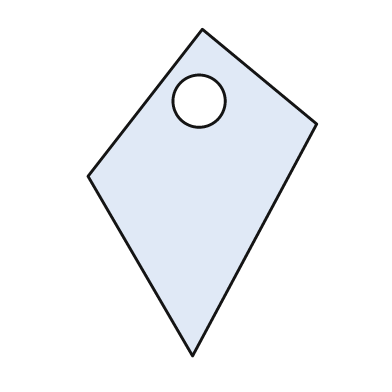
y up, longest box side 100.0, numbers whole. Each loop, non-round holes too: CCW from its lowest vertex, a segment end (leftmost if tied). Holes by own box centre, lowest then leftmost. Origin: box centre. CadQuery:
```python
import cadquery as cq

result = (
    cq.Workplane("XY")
    .moveTo(-3.0, -50.0)
    .lineTo(35.0, 21.0)
    .lineTo(0.0, 50.0)
    .lineTo(-35.0, 5.0)
    .close()
    .moveTo(-1.0, 28.0)
    .circle(8.0)
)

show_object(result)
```